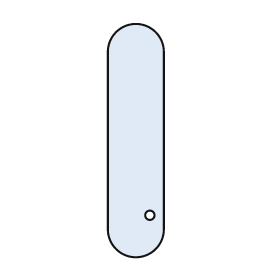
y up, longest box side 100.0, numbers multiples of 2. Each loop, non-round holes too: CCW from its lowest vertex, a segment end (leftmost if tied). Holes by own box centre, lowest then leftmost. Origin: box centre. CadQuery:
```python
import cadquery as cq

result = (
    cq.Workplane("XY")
    .moveTo(-12.0, -38.0)
    .threePointArc((0.0, -50.0), (12.0, -38.0))
    .lineTo(12.0, 38.0)
    .threePointArc((0.0, 50.0), (-12.0, 38.0))
    .close()
    .moveTo(6.0, -32.0)
    .circle(2.0)
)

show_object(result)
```